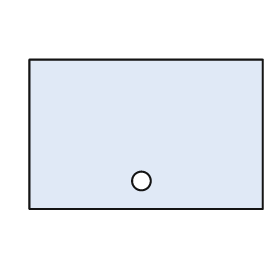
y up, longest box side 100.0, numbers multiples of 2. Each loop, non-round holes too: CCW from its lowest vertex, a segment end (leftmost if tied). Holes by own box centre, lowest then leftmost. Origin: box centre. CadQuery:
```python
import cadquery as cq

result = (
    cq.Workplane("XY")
    .moveTo(-50.0, -32.0)
    .lineTo(50.0, -32.0)
    .lineTo(50.0, 32.0)
    .lineTo(-50.0, 32.0)
    .close()
    .moveTo(-2.0, -20.0)
    .circle(4.0)
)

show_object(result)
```